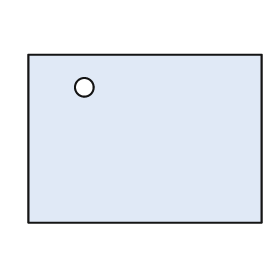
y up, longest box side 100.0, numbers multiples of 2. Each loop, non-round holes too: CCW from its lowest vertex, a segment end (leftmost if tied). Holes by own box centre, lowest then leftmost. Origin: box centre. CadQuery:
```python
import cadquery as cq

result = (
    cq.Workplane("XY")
    .moveTo(-50.0, -36.0)
    .lineTo(50.0, -36.0)
    .lineTo(50.0, 36.0)
    .lineTo(-50.0, 36.0)
    .close()
    .moveTo(-26.0, 22.0)
    .circle(4.0)
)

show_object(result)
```